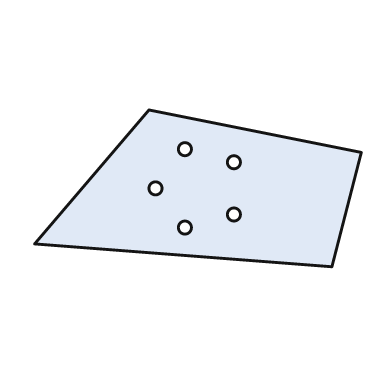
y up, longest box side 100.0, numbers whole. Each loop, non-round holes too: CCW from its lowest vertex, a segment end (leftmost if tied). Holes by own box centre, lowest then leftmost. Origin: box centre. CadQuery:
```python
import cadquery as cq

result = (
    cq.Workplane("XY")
    .moveTo(41.0, -24.0)
    .lineTo(50.0, 11.0)
    .lineTo(-15.0, 24.0)
    .lineTo(-50.0, -17.0)
    .close()
    .moveTo(-4.0, -12.0)
    .circle(2.0)
    .moveTo(11.0, -8.0)
    .circle(2.0)
    .moveTo(-13.0, 0.0)
    .circle(2.0)
    .moveTo(11.0, 8.0)
    .circle(2.0)
    .moveTo(-4.0, 12.0)
    .circle(2.0)
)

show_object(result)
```